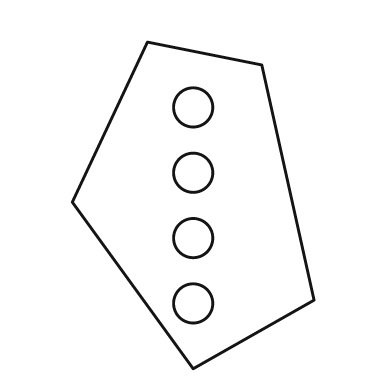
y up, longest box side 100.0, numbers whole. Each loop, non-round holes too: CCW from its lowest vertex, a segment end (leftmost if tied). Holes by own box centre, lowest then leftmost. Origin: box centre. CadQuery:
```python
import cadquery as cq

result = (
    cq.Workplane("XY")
    .moveTo(0.0, -50.0)
    .lineTo(37.0, -29.0)
    .lineTo(21.0, 43.0)
    .lineTo(-14.0, 50.0)
    .lineTo(-37.0, 1.0)
    .close()
    .moveTo(0.0, -30.0)
    .circle(6.0)
    .moveTo(0.0, -10.0)
    .circle(6.0)
    .moveTo(0.0, 10.0)
    .circle(6.0)
    .moveTo(0.0, 30.0)
    .circle(6.0)
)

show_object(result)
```